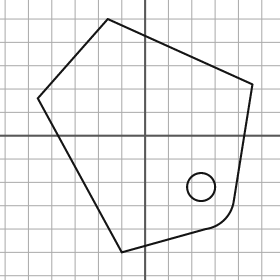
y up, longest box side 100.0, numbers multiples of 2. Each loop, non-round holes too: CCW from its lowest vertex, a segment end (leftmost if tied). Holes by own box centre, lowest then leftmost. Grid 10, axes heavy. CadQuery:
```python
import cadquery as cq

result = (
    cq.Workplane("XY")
    .moveTo(-10.0, -50.0)
    .lineTo(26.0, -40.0)
    .threePointArc((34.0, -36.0), (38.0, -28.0))
    .lineTo(46.0, 22.0)
    .lineTo(-16.0, 50.0)
    .lineTo(-46.0, 16.0)
    .close()
    .moveTo(24.0, -22.0)
    .circle(6.0)
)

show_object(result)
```